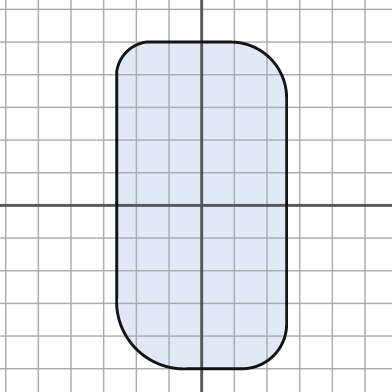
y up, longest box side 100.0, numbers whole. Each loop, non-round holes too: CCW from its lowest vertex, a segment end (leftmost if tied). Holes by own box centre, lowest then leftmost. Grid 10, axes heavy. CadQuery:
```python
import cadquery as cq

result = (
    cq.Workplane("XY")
    .moveTo(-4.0, -50.0)
    .lineTo(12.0, -50.0)
    .threePointArc((22.0, -46.0), (26.0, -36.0))
    .lineTo(26.0, 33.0)
    .threePointArc((21.0, 45.0), (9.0, 50.0))
    .lineTo(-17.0, 50.0)
    .threePointArc((-23.0, 47.0), (-26.0, 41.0))
    .lineTo(-26.0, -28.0)
    .threePointArc((-20.0, -44.0), (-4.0, -50.0))
    .close()
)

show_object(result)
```